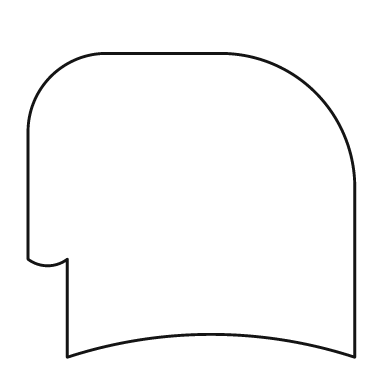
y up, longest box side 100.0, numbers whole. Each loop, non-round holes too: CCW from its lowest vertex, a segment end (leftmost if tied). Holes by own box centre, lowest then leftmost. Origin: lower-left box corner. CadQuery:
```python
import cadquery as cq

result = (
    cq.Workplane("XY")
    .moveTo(12.0, 0.0)
    .threePointArc((56.0, 7.0), (100.0, 0.0))
    .lineTo(100.0, 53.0)
    .threePointArc((88.0, 81.0), (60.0, 93.0))
    .lineTo(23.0, 93.0)
    .threePointArc((7.0, 86.0), (0.0, 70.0))
    .lineTo(0.0, 30.0)
    .threePointArc((6.0, 28.0), (12.0, 30.0))
    .close()
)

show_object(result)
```